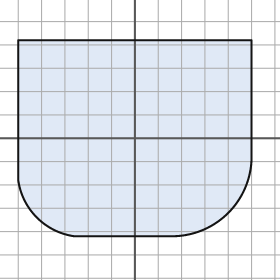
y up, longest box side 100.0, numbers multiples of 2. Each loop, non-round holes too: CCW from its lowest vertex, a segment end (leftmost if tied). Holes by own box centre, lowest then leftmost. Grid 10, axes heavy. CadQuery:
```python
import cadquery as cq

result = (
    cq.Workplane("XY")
    .moveTo(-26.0, -42.0)
    .lineTo(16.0, -42.0)
    .threePointArc((40.0, -32.0), (50.0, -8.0))
    .lineTo(50.0, 42.0)
    .lineTo(-50.0, 42.0)
    .lineTo(-50.0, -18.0)
    .threePointArc((-42.0, -34.0), (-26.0, -42.0))
    .close()
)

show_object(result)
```